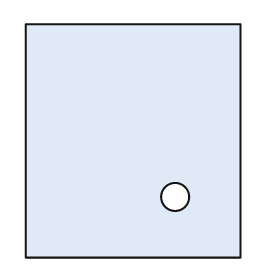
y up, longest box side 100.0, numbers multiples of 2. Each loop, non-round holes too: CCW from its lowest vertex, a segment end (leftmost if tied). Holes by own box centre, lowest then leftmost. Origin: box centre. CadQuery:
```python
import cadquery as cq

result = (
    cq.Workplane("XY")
    .moveTo(-46.0, -50.0)
    .lineTo(46.0, -50.0)
    .lineTo(46.0, 50.0)
    .lineTo(-46.0, 50.0)
    .close()
    .moveTo(18.0, -24.0)
    .circle(6.0)
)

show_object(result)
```